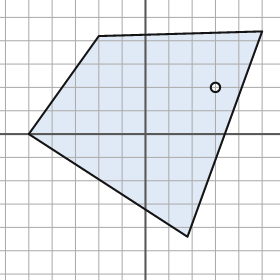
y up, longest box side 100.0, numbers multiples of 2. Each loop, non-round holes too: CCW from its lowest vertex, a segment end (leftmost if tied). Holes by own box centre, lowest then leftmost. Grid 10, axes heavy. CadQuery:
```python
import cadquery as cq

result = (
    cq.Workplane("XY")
    .moveTo(18.0, -44.0)
    .lineTo(50.0, 44.0)
    .lineTo(-20.0, 42.0)
    .lineTo(-50.0, 0.0)
    .close()
    .moveTo(30.0, 20.0)
    .circle(2.0)
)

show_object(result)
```